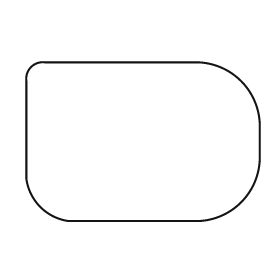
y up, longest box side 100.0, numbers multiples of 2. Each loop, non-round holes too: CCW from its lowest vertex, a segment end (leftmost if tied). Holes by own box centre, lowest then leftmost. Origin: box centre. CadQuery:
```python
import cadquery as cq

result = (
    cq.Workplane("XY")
    .moveTo(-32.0, -34.0)
    .lineTo(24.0, -34.0)
    .threePointArc((42.0, -26.0), (50.0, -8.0))
    .lineTo(50.0, 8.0)
    .threePointArc((42.0, 26.0), (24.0, 34.0))
    .lineTo(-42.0, 34.0)
    .threePointArc((-48.0, 32.0), (-50.0, 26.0))
    .lineTo(-50.0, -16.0)
    .threePointArc((-44.0, -28.0), (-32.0, -34.0))
    .close()
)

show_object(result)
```